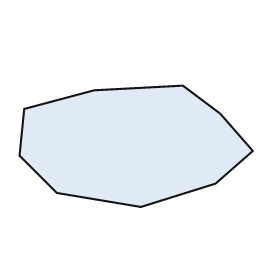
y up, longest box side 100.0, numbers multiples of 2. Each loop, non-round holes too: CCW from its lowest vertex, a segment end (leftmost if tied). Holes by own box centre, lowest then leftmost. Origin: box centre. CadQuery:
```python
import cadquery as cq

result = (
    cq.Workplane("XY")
    .moveTo(2.0, -26.0)
    .lineTo(34.0, -16.0)
    .lineTo(50.0, -2.0)
    .lineTo(36.0, 14.0)
    .lineTo(20.0, 26.0)
    .lineTo(-18.0, 24.0)
    .lineTo(-48.0, 16.0)
    .lineTo(-50.0, -4.0)
    .lineTo(-34.0, -20.0)
    .close()
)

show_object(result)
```